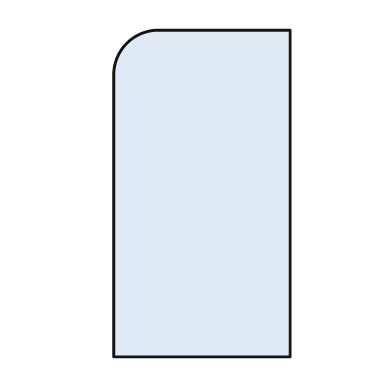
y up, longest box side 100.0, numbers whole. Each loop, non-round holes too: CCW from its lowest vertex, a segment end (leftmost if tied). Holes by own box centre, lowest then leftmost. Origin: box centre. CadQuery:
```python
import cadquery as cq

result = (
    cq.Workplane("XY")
    .moveTo(-27.0, -50.0)
    .lineTo(27.0, -50.0)
    .lineTo(27.0, 50.0)
    .lineTo(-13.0, 50.0)
    .threePointArc((-23.0, 46.0), (-27.0, 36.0))
    .close()
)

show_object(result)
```